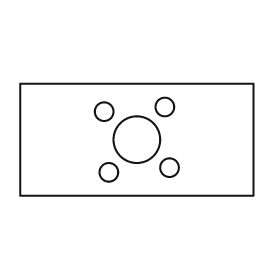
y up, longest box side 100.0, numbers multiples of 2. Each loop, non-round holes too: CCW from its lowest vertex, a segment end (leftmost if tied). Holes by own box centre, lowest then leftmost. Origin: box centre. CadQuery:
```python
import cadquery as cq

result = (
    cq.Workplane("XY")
    .moveTo(-50.0, -24.0)
    .lineTo(50.0, -24.0)
    .lineTo(50.0, 24.0)
    .lineTo(-50.0, 24.0)
    .close()
    .moveTo(-12.0, -14.0)
    .circle(4.0)
    .moveTo(14.0, -12.0)
    .circle(4.0)
    .moveTo(0.0, 0.0)
    .circle(10.0)
    .moveTo(-14.0, 12.0)
    .circle(4.0)
    .moveTo(12.0, 14.0)
    .circle(4.0)
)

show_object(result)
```